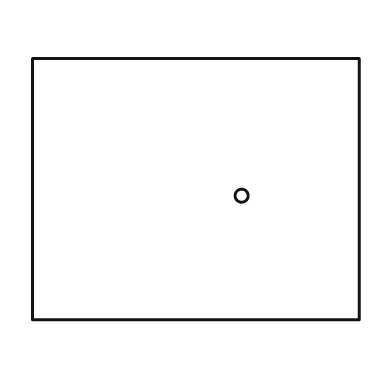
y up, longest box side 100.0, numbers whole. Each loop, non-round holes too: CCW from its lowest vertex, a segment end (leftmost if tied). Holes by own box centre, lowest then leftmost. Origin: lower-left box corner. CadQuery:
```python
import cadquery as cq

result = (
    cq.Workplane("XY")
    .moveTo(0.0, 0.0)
    .lineTo(100.0, 0.0)
    .lineTo(100.0, 80.0)
    .lineTo(0.0, 80.0)
    .close()
    .moveTo(64.0, 38.0)
    .circle(2.0)
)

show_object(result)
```